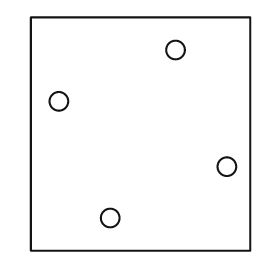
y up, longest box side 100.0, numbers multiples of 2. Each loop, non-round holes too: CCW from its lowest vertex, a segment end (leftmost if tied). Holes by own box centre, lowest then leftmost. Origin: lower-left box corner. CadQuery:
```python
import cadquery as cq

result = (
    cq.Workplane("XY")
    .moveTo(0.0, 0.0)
    .lineTo(94.0, 0.0)
    .lineTo(94.0, 100.0)
    .lineTo(0.0, 100.0)
    .close()
    .moveTo(34.0, 14.0)
    .circle(4.0)
    .moveTo(84.0, 36.0)
    .circle(4.0)
    .moveTo(12.0, 64.0)
    .circle(4.0)
    .moveTo(62.0, 86.0)
    .circle(4.0)
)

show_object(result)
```